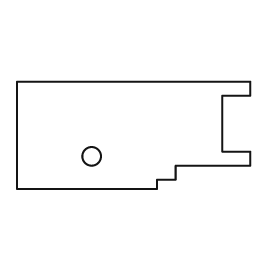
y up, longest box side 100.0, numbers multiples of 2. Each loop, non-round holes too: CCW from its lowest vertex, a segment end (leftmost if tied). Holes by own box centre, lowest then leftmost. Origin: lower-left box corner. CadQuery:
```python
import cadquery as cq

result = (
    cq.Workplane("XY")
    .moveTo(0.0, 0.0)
    .lineTo(60.0, 0.0)
    .lineTo(60.0, 4.0)
    .lineTo(68.0, 4.0)
    .lineTo(68.0, 10.0)
    .lineTo(100.0, 10.0)
    .lineTo(100.0, 16.0)
    .lineTo(88.0, 16.0)
    .lineTo(88.0, 40.0)
    .lineTo(100.0, 40.0)
    .lineTo(100.0, 46.0)
    .lineTo(0.0, 46.0)
    .close()
    .moveTo(32.0, 14.0)
    .circle(4.0)
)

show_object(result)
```